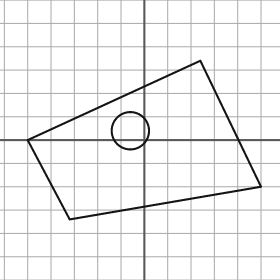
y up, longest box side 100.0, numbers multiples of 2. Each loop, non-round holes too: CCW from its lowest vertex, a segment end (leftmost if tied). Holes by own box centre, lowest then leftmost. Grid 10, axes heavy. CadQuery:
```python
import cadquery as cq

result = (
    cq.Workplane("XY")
    .moveTo(-32.0, -34.0)
    .lineTo(50.0, -20.0)
    .lineTo(24.0, 34.0)
    .lineTo(-50.0, 0.0)
    .close()
    .moveTo(-6.0, 4.0)
    .circle(8.0)
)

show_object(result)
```